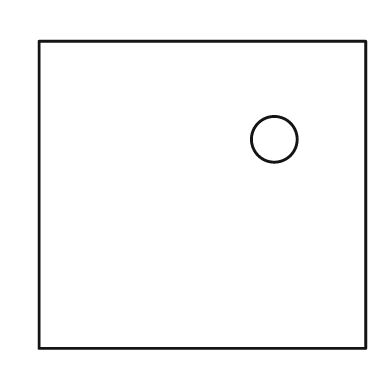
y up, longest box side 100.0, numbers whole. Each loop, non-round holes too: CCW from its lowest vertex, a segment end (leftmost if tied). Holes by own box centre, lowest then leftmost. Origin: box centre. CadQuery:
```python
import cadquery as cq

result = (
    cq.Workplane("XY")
    .moveTo(-50.0, -47.0)
    .lineTo(50.0, -47.0)
    .lineTo(50.0, 47.0)
    .lineTo(-50.0, 47.0)
    .close()
    .moveTo(22.0, 17.0)
    .circle(7.0)
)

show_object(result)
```